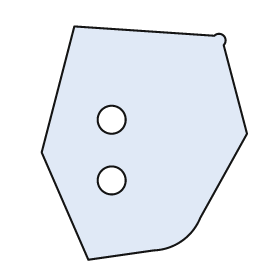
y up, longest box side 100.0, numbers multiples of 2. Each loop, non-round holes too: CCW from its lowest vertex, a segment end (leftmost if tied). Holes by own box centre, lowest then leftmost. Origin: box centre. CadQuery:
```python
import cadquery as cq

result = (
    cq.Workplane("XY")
    .moveTo(-24.0, -50.0)
    .lineTo(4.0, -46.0)
    .threePointArc((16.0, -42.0), (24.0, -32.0))
    .lineTo(44.0, 4.0)
    .lineTo(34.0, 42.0)
    .threePointArc((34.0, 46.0), (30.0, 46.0))
    .lineTo(-30.0, 50.0)
    .lineTo(-44.0, -4.0)
    .close()
    .moveTo(-14.0, -16.0)
    .circle(6.0)
    .moveTo(-14.0, 10.0)
    .circle(6.0)
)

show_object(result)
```